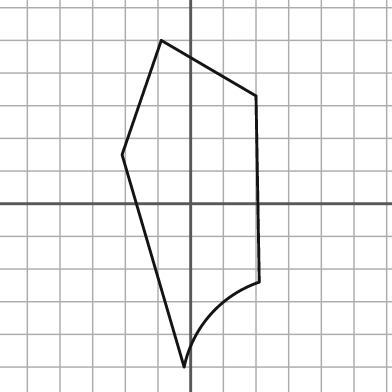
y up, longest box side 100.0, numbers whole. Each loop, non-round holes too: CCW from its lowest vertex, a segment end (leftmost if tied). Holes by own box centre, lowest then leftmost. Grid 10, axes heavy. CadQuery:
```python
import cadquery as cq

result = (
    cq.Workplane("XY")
    .moveTo(-2.0, -50.0)
    .threePointArc((6.0, -34.0), (21.0, -24.0))
    .lineTo(20.0, 33.0)
    .lineTo(-9.0, 50.0)
    .lineTo(-21.0, 15.0)
    .close()
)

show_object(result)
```